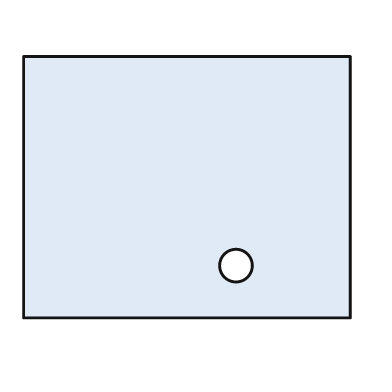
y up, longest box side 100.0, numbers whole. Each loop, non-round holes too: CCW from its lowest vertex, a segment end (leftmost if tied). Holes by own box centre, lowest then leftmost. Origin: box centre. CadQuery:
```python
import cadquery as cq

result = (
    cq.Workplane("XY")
    .moveTo(-50.0, -40.0)
    .lineTo(50.0, -40.0)
    .lineTo(50.0, 40.0)
    .lineTo(-50.0, 40.0)
    .close()
    .moveTo(15.0, -24.0)
    .circle(5.0)
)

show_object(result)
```